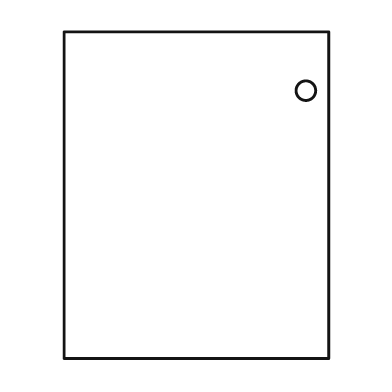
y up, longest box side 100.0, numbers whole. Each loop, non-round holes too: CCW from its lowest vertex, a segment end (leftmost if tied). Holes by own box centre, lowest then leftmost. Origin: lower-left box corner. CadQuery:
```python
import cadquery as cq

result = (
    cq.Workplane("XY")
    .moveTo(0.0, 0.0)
    .lineTo(81.0, 0.0)
    .lineTo(81.0, 100.0)
    .lineTo(0.0, 100.0)
    .close()
    .moveTo(74.0, 82.0)
    .circle(3.0)
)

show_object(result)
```